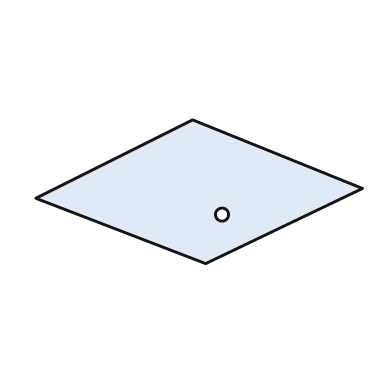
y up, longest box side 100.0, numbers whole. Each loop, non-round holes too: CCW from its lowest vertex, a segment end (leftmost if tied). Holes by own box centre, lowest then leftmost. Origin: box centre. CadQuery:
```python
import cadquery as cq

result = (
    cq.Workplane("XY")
    .moveTo(2.0, -22.0)
    .lineTo(50.0, 1.0)
    .lineTo(-2.0, 22.0)
    .lineTo(-50.0, -2.0)
    .close()
    .moveTo(7.0, -7.0)
    .circle(2.0)
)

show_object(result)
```